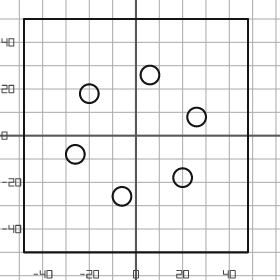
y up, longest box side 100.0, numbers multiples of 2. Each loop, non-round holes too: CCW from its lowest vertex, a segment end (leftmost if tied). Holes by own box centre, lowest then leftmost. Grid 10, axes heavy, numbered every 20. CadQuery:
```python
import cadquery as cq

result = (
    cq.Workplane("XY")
    .moveTo(-48.0, -50.0)
    .lineTo(48.0, -50.0)
    .lineTo(48.0, 50.0)
    .lineTo(-48.0, 50.0)
    .close()
    .moveTo(-6.0, -26.0)
    .circle(4.0)
    .moveTo(20.0, -18.0)
    .circle(4.0)
    .moveTo(-26.0, -8.0)
    .circle(4.0)
    .moveTo(26.0, 8.0)
    .circle(4.0)
    .moveTo(-20.0, 18.0)
    .circle(4.0)
    .moveTo(6.0, 26.0)
    .circle(4.0)
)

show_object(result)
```